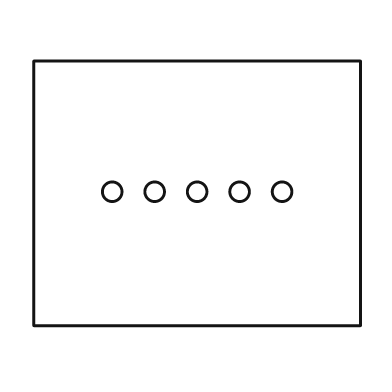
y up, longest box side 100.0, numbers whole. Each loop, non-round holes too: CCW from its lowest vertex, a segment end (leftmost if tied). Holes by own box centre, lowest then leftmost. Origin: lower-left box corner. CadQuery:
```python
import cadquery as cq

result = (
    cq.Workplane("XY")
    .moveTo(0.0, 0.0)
    .lineTo(100.0, 0.0)
    .lineTo(100.0, 81.0)
    .lineTo(0.0, 81.0)
    .close()
    .moveTo(24.0, 41.0)
    .circle(3.0)
    .moveTo(37.0, 41.0)
    .circle(3.0)
    .moveTo(50.0, 41.0)
    .circle(3.0)
    .moveTo(63.0, 41.0)
    .circle(3.0)
    .moveTo(76.0, 41.0)
    .circle(3.0)
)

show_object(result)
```